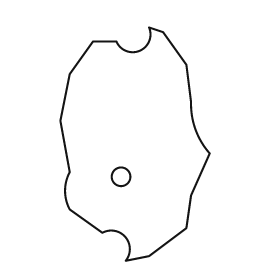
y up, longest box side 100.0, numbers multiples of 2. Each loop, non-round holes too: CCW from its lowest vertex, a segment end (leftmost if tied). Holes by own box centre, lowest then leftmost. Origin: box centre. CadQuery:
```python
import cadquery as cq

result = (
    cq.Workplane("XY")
    .moveTo(-4.0, -50.0)
    .lineTo(6.0, -48.0)
    .lineTo(22.0, -36.0)
    .lineTo(24.0, -22.0)
    .lineTo(32.0, -4.0)
    .threePointArc((26.0, 6.0), (24.0, 18.0))
    .lineTo(22.0, 34.0)
    .lineTo(12.0, 48.0)
    .lineTo(6.0, 50.0)
    .threePointArc((2.0, 40.0), (-8.0, 44.0))
    .lineTo(-18.0, 44.0)
    .lineTo(-28.0, 30.0)
    .lineTo(-32.0, 10.0)
    .lineTo(-28.0, -12.0)
    .threePointArc((-30.0, -20.0), (-28.0, -28.0))
    .lineTo(-14.0, -38.0)
    .threePointArc((-4.0, -40.0), (-4.0, -50.0))
    .close()
    .moveTo(-6.0, -14.0)
    .circle(4.0)
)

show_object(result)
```